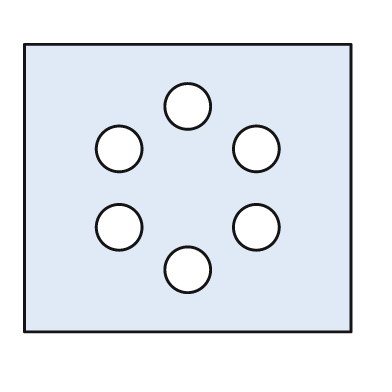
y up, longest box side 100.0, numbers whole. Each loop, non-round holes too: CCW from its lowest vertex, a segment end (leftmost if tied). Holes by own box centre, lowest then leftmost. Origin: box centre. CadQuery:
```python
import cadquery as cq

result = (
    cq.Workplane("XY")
    .moveTo(-50.0, -44.0)
    .lineTo(50.0, -44.0)
    .lineTo(50.0, 44.0)
    .lineTo(-50.0, 44.0)
    .close()
    .moveTo(0.0, -25.0)
    .circle(7.0)
    .moveTo(-21.0, -12.0)
    .circle(7.0)
    .moveTo(21.0, -12.0)
    .circle(7.0)
    .moveTo(-21.0, 12.0)
    .circle(7.0)
    .moveTo(21.0, 12.0)
    .circle(7.0)
    .moveTo(0.0, 25.0)
    .circle(7.0)
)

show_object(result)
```